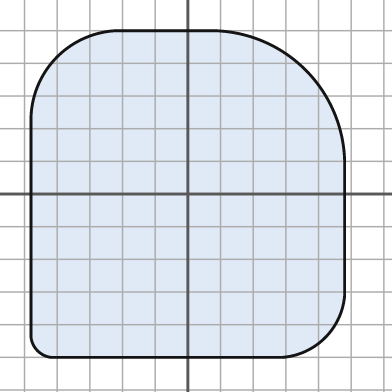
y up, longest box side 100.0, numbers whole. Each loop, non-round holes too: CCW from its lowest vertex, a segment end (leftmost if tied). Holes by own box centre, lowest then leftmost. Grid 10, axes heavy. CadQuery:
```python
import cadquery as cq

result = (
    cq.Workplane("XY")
    .moveTo(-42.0, -50.0)
    .lineTo(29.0, -50.0)
    .threePointArc((42.0, -44.0), (48.0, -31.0))
    .lineTo(48.0, 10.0)
    .threePointArc((36.0, 38.0), (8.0, 50.0))
    .lineTo(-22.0, 50.0)
    .threePointArc((-40.0, 42.0), (-48.0, 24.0))
    .lineTo(-48.0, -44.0)
    .threePointArc((-46.0, -48.0), (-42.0, -50.0))
    .close()
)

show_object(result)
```